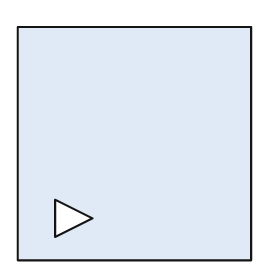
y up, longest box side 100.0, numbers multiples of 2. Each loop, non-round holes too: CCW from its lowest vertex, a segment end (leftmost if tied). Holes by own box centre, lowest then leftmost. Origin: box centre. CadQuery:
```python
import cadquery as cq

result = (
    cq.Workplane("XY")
    .moveTo(-50.0, -50.0)
    .lineTo(50.0, -50.0)
    .lineTo(50.0, 50.0)
    .lineTo(-50.0, 50.0)
    .close()
    .moveTo(-34.0, -40.0)
    .lineTo(-18.0, -32.0)
    .lineTo(-34.0, -24.0)
    .close()
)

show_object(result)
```